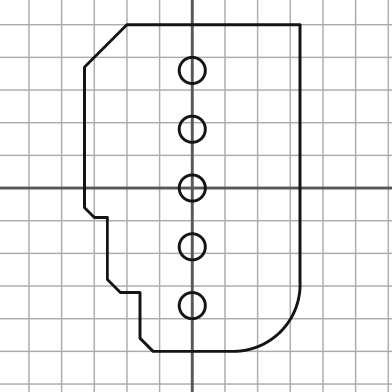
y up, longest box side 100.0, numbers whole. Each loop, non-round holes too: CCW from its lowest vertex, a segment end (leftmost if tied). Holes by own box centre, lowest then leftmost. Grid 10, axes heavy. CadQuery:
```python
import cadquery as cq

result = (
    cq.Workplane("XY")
    .moveTo(-12.0, -50.0)
    .lineTo(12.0, -50.0)
    .threePointArc((27.0, -44.0), (33.0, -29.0))
    .lineTo(33.0, 50.0)
    .lineTo(-20.0, 50.0)
    .lineTo(-33.0, 37.0)
    .lineTo(-33.0, -6.0)
    .lineTo(-30.0, -9.0)
    .lineTo(-26.0, -9.0)
    .lineTo(-26.0, -28.0)
    .lineTo(-22.0, -32.0)
    .lineTo(-16.0, -32.0)
    .lineTo(-16.0, -46.0)
    .close()
    .moveTo(0.0, -36.0)
    .circle(4.0)
    .moveTo(0.0, -18.0)
    .circle(4.0)
    .moveTo(0.0, 0.0)
    .circle(4.0)
    .moveTo(0.0, 18.0)
    .circle(4.0)
    .moveTo(0.0, 36.0)
    .circle(4.0)
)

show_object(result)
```